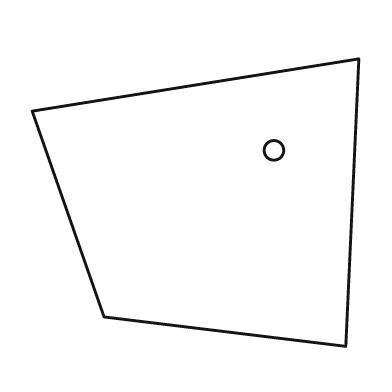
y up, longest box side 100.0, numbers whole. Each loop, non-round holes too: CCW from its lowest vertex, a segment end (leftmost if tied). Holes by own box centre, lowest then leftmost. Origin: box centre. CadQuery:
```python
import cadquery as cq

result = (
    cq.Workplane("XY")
    .moveTo(46.0, -44.0)
    .lineTo(50.0, 44.0)
    .lineTo(-50.0, 28.0)
    .lineTo(-28.0, -35.0)
    .close()
    .moveTo(24.0, 16.0)
    .circle(3.0)
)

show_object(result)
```